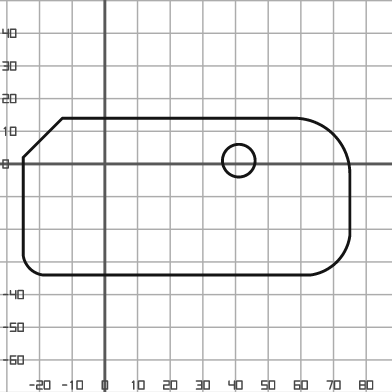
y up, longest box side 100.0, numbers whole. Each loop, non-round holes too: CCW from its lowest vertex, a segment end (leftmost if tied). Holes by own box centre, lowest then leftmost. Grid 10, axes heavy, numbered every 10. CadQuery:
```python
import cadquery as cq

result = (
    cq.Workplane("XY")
    .moveTo(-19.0, -34.0)
    .lineTo(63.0, -34.0)
    .threePointArc((71.0, -30.0), (75.0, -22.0))
    .lineTo(75.0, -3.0)
    .threePointArc((70.0, 9.0), (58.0, 14.0))
    .lineTo(-13.0, 14.0)
    .lineTo(-25.0, 2.0)
    .lineTo(-25.0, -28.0)
    .threePointArc((-23.0, -32.0), (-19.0, -34.0))
    .close()
    .moveTo(41.0, 1.0)
    .circle(5.0)
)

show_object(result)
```